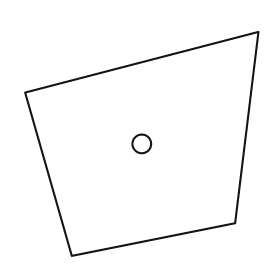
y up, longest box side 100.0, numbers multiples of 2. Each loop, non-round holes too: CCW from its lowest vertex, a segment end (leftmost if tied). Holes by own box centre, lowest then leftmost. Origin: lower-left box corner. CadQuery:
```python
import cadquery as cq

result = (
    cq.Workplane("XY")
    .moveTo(20.0, 0.0)
    .lineTo(90.0, 14.0)
    .lineTo(100.0, 96.0)
    .lineTo(0.0, 70.0)
    .close()
    .moveTo(50.0, 48.0)
    .circle(4.0)
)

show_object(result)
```